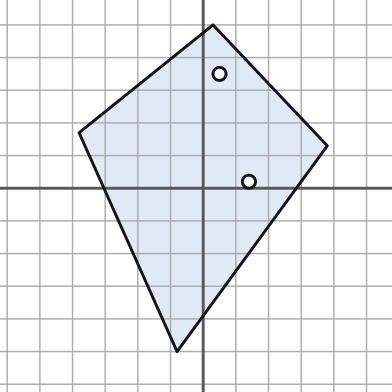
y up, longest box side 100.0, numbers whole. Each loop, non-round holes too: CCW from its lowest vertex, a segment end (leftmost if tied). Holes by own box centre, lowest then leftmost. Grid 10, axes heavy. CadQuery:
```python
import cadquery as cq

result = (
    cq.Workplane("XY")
    .moveTo(-8.0, -50.0)
    .lineTo(38.0, 13.0)
    .lineTo(3.0, 50.0)
    .lineTo(-38.0, 17.0)
    .close()
    .moveTo(14.0, 2.0)
    .circle(2.0)
    .moveTo(5.0, 35.0)
    .circle(2.0)
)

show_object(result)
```